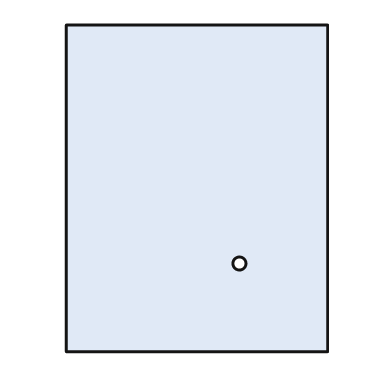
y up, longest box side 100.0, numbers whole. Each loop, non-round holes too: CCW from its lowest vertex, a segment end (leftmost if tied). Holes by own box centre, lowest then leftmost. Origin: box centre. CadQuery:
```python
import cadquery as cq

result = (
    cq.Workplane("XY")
    .moveTo(-40.0, -50.0)
    .lineTo(40.0, -50.0)
    .lineTo(40.0, 50.0)
    .lineTo(-40.0, 50.0)
    .close()
    .moveTo(13.0, -23.0)
    .circle(2.0)
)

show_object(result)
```